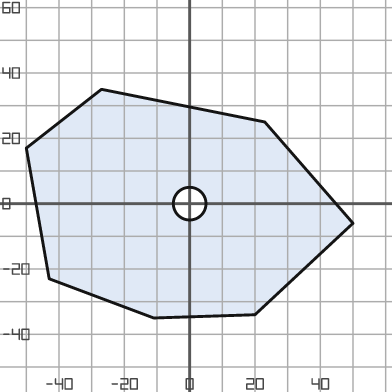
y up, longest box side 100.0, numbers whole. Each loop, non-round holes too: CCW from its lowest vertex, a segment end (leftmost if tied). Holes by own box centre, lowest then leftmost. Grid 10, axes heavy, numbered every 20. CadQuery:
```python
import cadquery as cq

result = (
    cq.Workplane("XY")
    .moveTo(-11.0, -35.0)
    .lineTo(20.0, -34.0)
    .lineTo(50.0, -6.0)
    .lineTo(23.0, 25.0)
    .lineTo(-27.0, 35.0)
    .lineTo(-50.0, 17.0)
    .lineTo(-43.0, -23.0)
    .close()
    .moveTo(0.0, 0.0)
    .circle(5.0)
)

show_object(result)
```